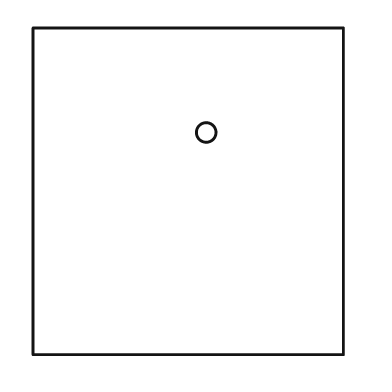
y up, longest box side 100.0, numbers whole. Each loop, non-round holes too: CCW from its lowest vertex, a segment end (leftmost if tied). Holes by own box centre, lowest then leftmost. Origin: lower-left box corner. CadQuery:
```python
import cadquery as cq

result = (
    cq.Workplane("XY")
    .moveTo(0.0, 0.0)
    .lineTo(95.0, 0.0)
    .lineTo(95.0, 100.0)
    .lineTo(0.0, 100.0)
    .close()
    .moveTo(53.0, 68.0)
    .circle(3.0)
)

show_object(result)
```